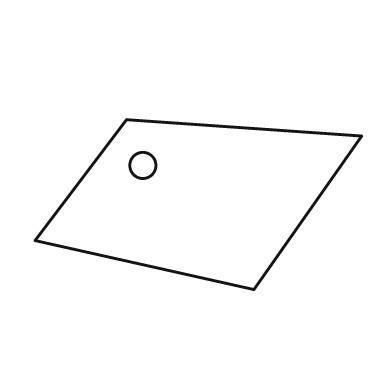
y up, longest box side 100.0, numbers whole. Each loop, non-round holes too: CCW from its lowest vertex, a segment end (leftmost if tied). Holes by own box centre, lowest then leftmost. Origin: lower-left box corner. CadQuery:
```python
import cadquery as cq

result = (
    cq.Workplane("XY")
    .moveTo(67.0, 0.0)
    .lineTo(100.0, 47.0)
    .lineTo(28.0, 52.0)
    .lineTo(0.0, 15.0)
    .close()
    .moveTo(33.0, 38.0)
    .circle(4.0)
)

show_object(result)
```